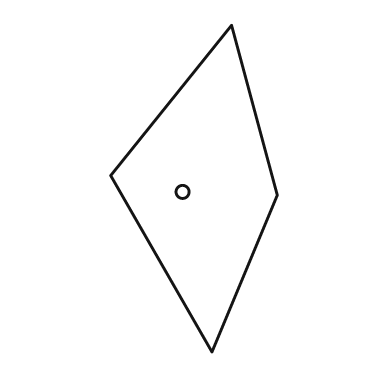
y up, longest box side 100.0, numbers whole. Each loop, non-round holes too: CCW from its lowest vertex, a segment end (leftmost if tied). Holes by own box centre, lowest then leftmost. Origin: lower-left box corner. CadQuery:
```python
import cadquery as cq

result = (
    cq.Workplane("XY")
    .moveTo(31.0, 0.0)
    .lineTo(51.0, 48.0)
    .lineTo(37.0, 100.0)
    .lineTo(0.0, 54.0)
    .close()
    .moveTo(22.0, 49.0)
    .circle(2.0)
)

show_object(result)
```